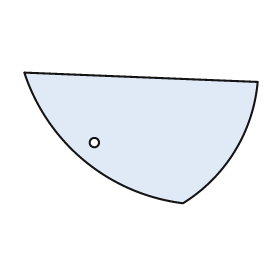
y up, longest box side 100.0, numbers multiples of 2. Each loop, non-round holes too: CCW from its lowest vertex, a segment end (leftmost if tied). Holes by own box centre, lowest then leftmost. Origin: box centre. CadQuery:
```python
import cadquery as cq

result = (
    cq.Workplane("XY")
    .moveTo(18.0, -28.0)
    .threePointArc((40.0, -6.0), (50.0, 24.0))
    .lineTo(-50.0, 28.0)
    .threePointArc((-24.0, -10.0), (18.0, -28.0))
    .close()
    .moveTo(-20.0, -2.0)
    .circle(2.0)
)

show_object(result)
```